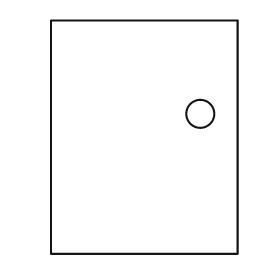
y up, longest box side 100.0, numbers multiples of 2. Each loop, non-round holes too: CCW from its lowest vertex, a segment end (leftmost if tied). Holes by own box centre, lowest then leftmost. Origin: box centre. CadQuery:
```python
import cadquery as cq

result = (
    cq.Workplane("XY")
    .moveTo(-40.0, -50.0)
    .lineTo(40.0, -50.0)
    .lineTo(40.0, 50.0)
    .lineTo(-40.0, 50.0)
    .close()
    .moveTo(24.0, 10.0)
    .circle(6.0)
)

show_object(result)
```